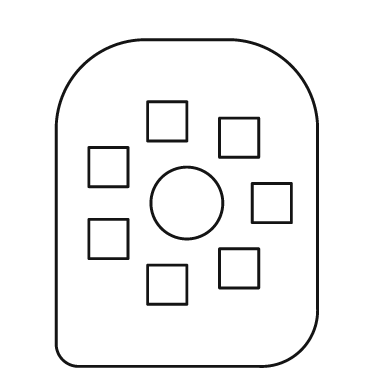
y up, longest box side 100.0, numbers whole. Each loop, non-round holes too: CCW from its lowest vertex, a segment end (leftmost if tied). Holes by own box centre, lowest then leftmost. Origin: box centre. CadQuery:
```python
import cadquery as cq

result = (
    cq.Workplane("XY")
    .moveTo(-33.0, -50.0)
    .lineTo(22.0, -50.0)
    .threePointArc((35.0, -45.0), (40.0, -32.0))
    .lineTo(40.0, 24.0)
    .threePointArc((32.0, 42.0), (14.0, 50.0))
    .lineTo(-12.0, 50.0)
    .threePointArc((-32.0, 42.0), (-40.0, 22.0))
    .lineTo(-40.0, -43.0)
    .threePointArc((-38.0, -48.0), (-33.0, -50.0))
    .close()
    .moveTo(-12.0, -31.0)
    .lineTo(0.0, -31.0)
    .lineTo(0.0, -19.0)
    .lineTo(-12.0, -19.0)
    .close()
    .moveTo(10.0, -26.0)
    .lineTo(22.0, -26.0)
    .lineTo(22.0, -14.0)
    .lineTo(10.0, -14.0)
    .close()
    .moveTo(-30.0, -17.0)
    .lineTo(-18.0, -17.0)
    .lineTo(-18.0, -5.0)
    .lineTo(-30.0, -5.0)
    .close()
    .moveTo(0.0, 0.0)
    .circle(11.0)
    .moveTo(20.0, -6.0)
    .lineTo(32.0, -6.0)
    .lineTo(32.0, 6.0)
    .lineTo(20.0, 6.0)
    .close()
    .moveTo(-30.0, 5.0)
    .lineTo(-18.0, 5.0)
    .lineTo(-18.0, 17.0)
    .lineTo(-30.0, 17.0)
    .close()
    .moveTo(10.0, 14.0)
    .lineTo(22.0, 14.0)
    .lineTo(22.0, 26.0)
    .lineTo(10.0, 26.0)
    .close()
    .moveTo(-12.0, 19.0)
    .lineTo(0.0, 19.0)
    .lineTo(0.0, 31.0)
    .lineTo(-12.0, 31.0)
    .close()
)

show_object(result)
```